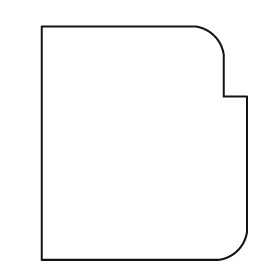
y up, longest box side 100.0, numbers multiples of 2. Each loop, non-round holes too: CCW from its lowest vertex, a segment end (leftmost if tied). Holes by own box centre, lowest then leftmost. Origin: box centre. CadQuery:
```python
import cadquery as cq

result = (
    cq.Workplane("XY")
    .moveTo(-44.0, -50.0)
    .lineTo(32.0, -50.0)
    .threePointArc((40.0, -46.0), (44.0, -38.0))
    .lineTo(44.0, 20.0)
    .lineTo(34.0, 20.0)
    .lineTo(34.0, 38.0)
    .threePointArc((30.0, 46.0), (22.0, 50.0))
    .lineTo(-44.0, 50.0)
    .close()
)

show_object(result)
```